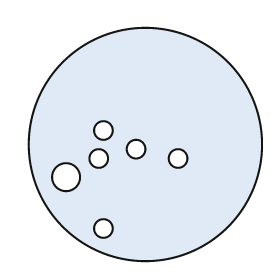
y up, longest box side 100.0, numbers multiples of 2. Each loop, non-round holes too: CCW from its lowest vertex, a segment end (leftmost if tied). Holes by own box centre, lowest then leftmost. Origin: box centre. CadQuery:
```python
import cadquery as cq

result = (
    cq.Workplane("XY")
    .moveTo(0.0, 0.0)
    .circle(50.0)
    .moveTo(-18.0, -36.0)
    .circle(4.0)
    .moveTo(-34.0, -14.0)
    .circle(6.0)
    .moveTo(-20.0, -6.0)
    .circle(4.0)
    .moveTo(14.0, -6.0)
    .circle(4.0)
    .moveTo(-4.0, -2.0)
    .circle(4.0)
    .moveTo(-18.0, 6.0)
    .circle(4.0)
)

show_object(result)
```